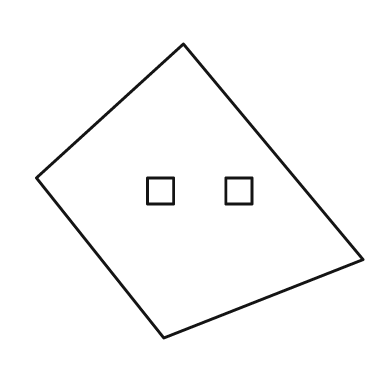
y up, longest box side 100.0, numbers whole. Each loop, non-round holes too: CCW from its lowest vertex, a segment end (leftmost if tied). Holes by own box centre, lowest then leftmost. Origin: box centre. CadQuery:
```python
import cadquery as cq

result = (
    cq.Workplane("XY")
    .moveTo(-11.0, -45.0)
    .lineTo(50.0, -21.0)
    .lineTo(-5.0, 45.0)
    .lineTo(-50.0, 4.0)
    .close()
    .moveTo(-16.0, -4.0)
    .lineTo(-8.0, -4.0)
    .lineTo(-8.0, 4.0)
    .lineTo(-16.0, 4.0)
    .close()
    .moveTo(8.0, -4.0)
    .lineTo(16.0, -4.0)
    .lineTo(16.0, 4.0)
    .lineTo(8.0, 4.0)
    .close()
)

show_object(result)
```